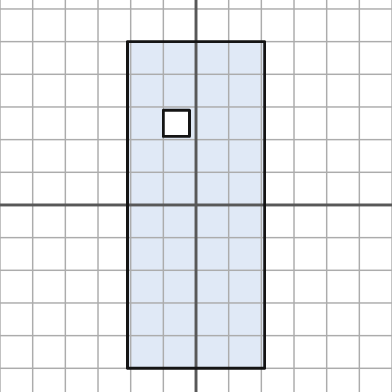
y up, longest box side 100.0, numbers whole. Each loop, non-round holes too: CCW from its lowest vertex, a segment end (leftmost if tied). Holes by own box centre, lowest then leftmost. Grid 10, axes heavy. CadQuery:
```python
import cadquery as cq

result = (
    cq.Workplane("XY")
    .moveTo(-21.0, -50.0)
    .lineTo(21.0, -50.0)
    .lineTo(21.0, 50.0)
    .lineTo(-21.0, 50.0)
    .close()
    .moveTo(-10.0, 21.0)
    .lineTo(-2.0, 21.0)
    .lineTo(-2.0, 29.0)
    .lineTo(-10.0, 29.0)
    .close()
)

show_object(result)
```